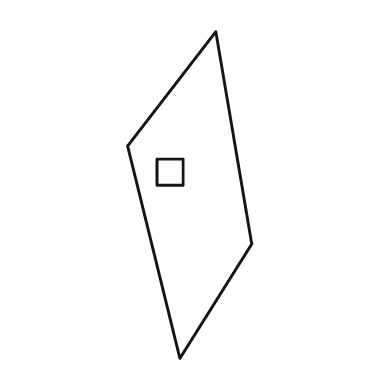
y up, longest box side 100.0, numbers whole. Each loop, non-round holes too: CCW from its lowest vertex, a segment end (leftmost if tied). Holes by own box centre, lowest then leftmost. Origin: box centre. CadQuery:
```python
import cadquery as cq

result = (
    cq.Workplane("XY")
    .moveTo(-3.0, -50.0)
    .lineTo(19.0, -15.0)
    .lineTo(8.0, 50.0)
    .lineTo(-19.0, 15.0)
    .close()
    .moveTo(-10.0, 3.0)
    .lineTo(-2.0, 3.0)
    .lineTo(-2.0, 11.0)
    .lineTo(-10.0, 11.0)
    .close()
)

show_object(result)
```